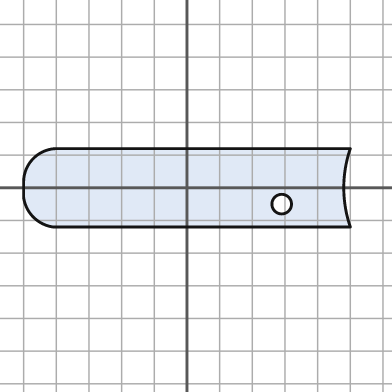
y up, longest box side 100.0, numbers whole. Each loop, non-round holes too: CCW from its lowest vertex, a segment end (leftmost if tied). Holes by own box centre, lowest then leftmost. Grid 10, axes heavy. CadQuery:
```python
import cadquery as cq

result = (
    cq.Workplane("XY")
    .moveTo(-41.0, -12.0)
    .lineTo(50.0, -12.0)
    .threePointArc((48.0, 0.0), (50.0, 12.0))
    .lineTo(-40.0, 12.0)
    .threePointArc((-47.0, 9.0), (-50.0, 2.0))
    .lineTo(-50.0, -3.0)
    .threePointArc((-47.0, -9.0), (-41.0, -12.0))
    .close()
    .moveTo(29.0, -5.0)
    .circle(3.0)
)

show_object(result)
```